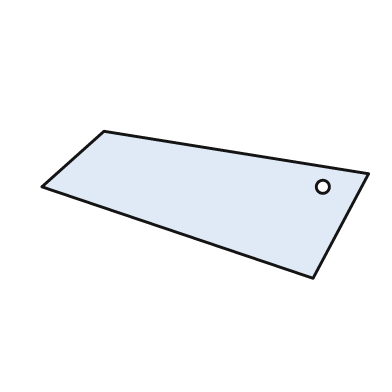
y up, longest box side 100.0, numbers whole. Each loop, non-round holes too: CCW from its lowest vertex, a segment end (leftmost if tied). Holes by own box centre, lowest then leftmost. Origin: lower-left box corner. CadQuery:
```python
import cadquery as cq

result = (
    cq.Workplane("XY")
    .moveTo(83.0, 0.0)
    .lineTo(100.0, 32.0)
    .lineTo(19.0, 45.0)
    .lineTo(0.0, 28.0)
    .close()
    .moveTo(86.0, 28.0)
    .circle(2.0)
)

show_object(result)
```